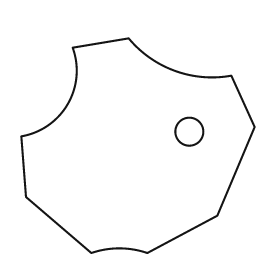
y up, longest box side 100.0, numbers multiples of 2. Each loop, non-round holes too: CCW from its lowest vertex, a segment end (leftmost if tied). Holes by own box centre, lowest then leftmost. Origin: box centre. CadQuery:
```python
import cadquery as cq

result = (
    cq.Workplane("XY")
    .moveTo(-20.0, -46.0)
    .threePointArc((-8.0, -44.0), (4.0, -46.0))
    .lineTo(34.0, -30.0)
    .lineTo(50.0, 8.0)
    .lineTo(40.0, 30.0)
    .threePointArc((16.0, 32.0), (-4.0, 46.0))
    .lineTo(-28.0, 42.0)
    .threePointArc((-30.0, 18.0), (-50.0, 4.0))
    .lineTo(-48.0, -22.0)
    .close()
    .moveTo(22.0, 6.0)
    .circle(6.0)
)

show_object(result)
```